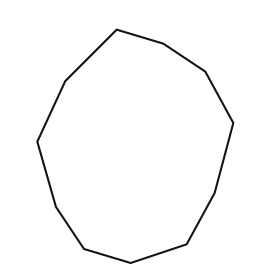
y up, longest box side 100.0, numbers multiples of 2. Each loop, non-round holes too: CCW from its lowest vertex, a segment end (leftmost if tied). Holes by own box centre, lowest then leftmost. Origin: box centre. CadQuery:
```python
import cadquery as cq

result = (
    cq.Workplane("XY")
    .moveTo(-2.0, -50.0)
    .lineTo(22.0, -42.0)
    .lineTo(34.0, -20.0)
    .lineTo(42.0, 10.0)
    .lineTo(30.0, 32.0)
    .lineTo(12.0, 44.0)
    .lineTo(-8.0, 50.0)
    .lineTo(-30.0, 28.0)
    .lineTo(-42.0, 2.0)
    .lineTo(-34.0, -26.0)
    .lineTo(-22.0, -44.0)
    .close()
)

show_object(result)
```